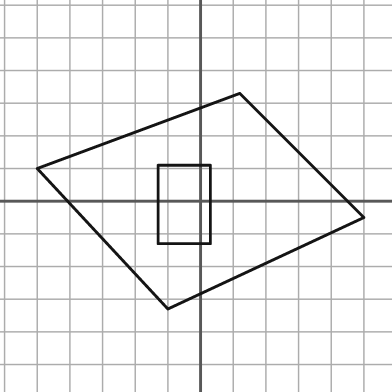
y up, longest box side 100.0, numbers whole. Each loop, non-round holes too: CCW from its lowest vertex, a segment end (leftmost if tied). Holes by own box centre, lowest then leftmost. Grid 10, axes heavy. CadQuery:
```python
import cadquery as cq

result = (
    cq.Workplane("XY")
    .moveTo(-10.0, -33.0)
    .lineTo(50.0, -5.0)
    .lineTo(12.0, 33.0)
    .lineTo(-50.0, 10.0)
    .close()
    .moveTo(-13.0, -13.0)
    .lineTo(3.0, -13.0)
    .lineTo(3.0, 11.0)
    .lineTo(-13.0, 11.0)
    .close()
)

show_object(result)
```